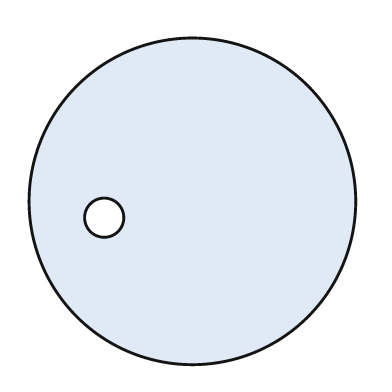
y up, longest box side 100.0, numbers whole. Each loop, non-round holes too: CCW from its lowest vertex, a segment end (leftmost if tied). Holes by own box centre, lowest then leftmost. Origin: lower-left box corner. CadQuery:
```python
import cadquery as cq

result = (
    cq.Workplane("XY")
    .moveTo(50.0, 50.0)
    .circle(50.0)
    .moveTo(23.0, 45.0)
    .circle(6.0)
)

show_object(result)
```